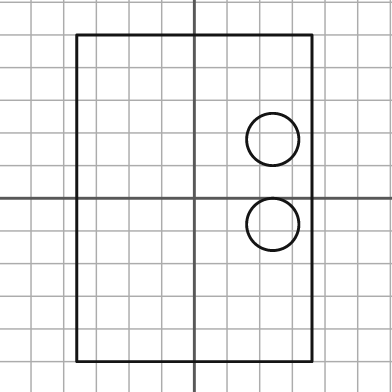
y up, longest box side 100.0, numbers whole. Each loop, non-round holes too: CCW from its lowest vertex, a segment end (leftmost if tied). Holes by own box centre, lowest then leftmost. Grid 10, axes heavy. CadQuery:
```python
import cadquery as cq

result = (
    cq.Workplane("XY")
    .moveTo(-36.0, -50.0)
    .lineTo(36.0, -50.0)
    .lineTo(36.0, 50.0)
    .lineTo(-36.0, 50.0)
    .close()
    .moveTo(24.0, -8.0)
    .circle(8.0)
    .moveTo(24.0, 18.0)
    .circle(8.0)
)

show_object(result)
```